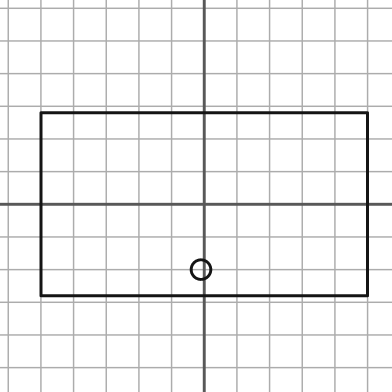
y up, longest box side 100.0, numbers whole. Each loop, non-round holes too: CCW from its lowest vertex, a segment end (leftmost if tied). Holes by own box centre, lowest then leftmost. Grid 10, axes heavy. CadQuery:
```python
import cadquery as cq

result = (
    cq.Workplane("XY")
    .moveTo(-50.0, -28.0)
    .lineTo(50.0, -28.0)
    .lineTo(50.0, 28.0)
    .lineTo(-50.0, 28.0)
    .close()
    .moveTo(-1.0, -20.0)
    .circle(3.0)
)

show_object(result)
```